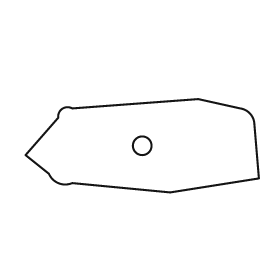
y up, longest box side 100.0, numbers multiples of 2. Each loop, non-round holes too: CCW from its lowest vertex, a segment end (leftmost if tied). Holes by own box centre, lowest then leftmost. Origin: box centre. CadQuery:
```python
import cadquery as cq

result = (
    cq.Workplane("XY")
    .moveTo(12.0, -20.0)
    .lineTo(50.0, -14.0)
    .lineTo(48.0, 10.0)
    .threePointArc((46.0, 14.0), (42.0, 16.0))
    .lineTo(24.0, 20.0)
    .lineTo(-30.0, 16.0)
    .threePointArc((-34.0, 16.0), (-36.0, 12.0))
    .lineTo(-50.0, -4.0)
    .lineTo(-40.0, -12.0)
    .threePointArc((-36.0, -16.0), (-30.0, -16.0))
    .close()
    .moveTo(0.0, 0.0)
    .circle(4.0)
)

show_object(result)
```